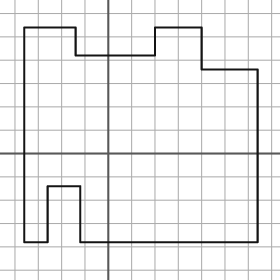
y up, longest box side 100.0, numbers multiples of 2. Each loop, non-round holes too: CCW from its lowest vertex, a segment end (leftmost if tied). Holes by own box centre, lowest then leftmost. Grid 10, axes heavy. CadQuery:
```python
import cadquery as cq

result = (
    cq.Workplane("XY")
    .moveTo(-36.0, -38.0)
    .lineTo(-26.0, -38.0)
    .lineTo(-26.0, -14.0)
    .lineTo(-12.0, -14.0)
    .lineTo(-12.0, -38.0)
    .lineTo(64.0, -38.0)
    .lineTo(64.0, 36.0)
    .lineTo(40.0, 36.0)
    .lineTo(40.0, 54.0)
    .lineTo(20.0, 54.0)
    .lineTo(20.0, 42.0)
    .lineTo(-14.0, 42.0)
    .lineTo(-14.0, 54.0)
    .lineTo(-36.0, 54.0)
    .close()
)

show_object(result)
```